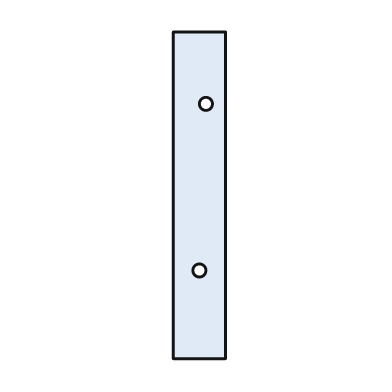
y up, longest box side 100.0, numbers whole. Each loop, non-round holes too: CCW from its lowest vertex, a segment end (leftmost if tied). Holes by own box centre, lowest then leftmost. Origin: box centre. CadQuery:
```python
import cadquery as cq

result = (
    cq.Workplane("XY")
    .moveTo(-8.0, -50.0)
    .lineTo(8.0, -50.0)
    .lineTo(8.0, 50.0)
    .lineTo(-8.0, 50.0)
    .close()
    .moveTo(0.0, -23.0)
    .circle(2.0)
    .moveTo(2.0, 28.0)
    .circle(2.0)
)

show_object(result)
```